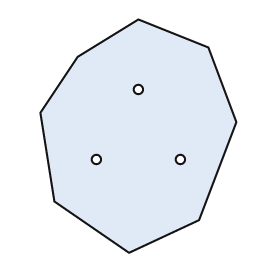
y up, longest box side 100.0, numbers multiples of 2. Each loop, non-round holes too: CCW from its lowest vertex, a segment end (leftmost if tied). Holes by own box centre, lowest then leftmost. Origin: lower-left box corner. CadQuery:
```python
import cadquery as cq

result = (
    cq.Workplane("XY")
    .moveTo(38.0, 0.0)
    .lineTo(68.0, 14.0)
    .lineTo(84.0, 56.0)
    .lineTo(72.0, 88.0)
    .lineTo(42.0, 100.0)
    .lineTo(16.0, 84.0)
    .lineTo(0.0, 60.0)
    .lineTo(6.0, 22.0)
    .close()
    .moveTo(24.0, 40.0)
    .circle(2.0)
    .moveTo(60.0, 40.0)
    .circle(2.0)
    .moveTo(42.0, 70.0)
    .circle(2.0)
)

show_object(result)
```